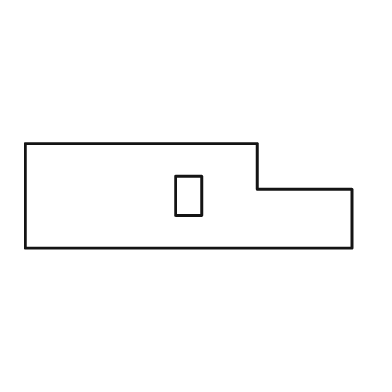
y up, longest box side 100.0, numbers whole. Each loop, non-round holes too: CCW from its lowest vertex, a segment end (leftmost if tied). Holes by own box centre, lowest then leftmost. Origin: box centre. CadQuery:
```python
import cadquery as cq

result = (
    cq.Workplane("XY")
    .moveTo(-50.0, -16.0)
    .lineTo(50.0, -16.0)
    .lineTo(50.0, 2.0)
    .lineTo(21.0, 2.0)
    .lineTo(21.0, 16.0)
    .lineTo(-50.0, 16.0)
    .close()
    .moveTo(-4.0, -6.0)
    .lineTo(4.0, -6.0)
    .lineTo(4.0, 6.0)
    .lineTo(-4.0, 6.0)
    .close()
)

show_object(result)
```